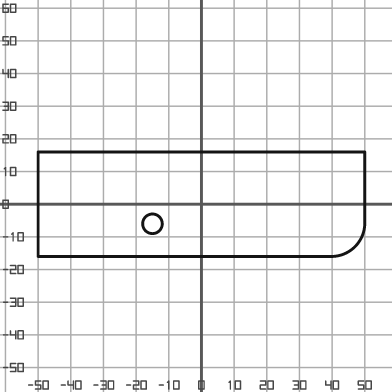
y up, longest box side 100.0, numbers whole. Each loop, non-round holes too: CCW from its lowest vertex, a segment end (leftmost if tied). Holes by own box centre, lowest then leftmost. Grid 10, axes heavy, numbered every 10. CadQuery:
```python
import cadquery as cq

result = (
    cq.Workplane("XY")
    .moveTo(-50.0, -16.0)
    .lineTo(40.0, -16.0)
    .threePointArc((47.0, -13.0), (50.0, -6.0))
    .lineTo(50.0, 16.0)
    .lineTo(-50.0, 16.0)
    .close()
    .moveTo(-15.0, -6.0)
    .circle(3.0)
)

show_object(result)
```